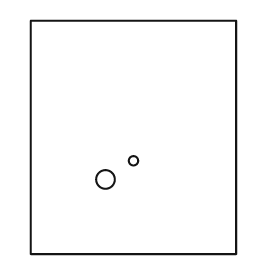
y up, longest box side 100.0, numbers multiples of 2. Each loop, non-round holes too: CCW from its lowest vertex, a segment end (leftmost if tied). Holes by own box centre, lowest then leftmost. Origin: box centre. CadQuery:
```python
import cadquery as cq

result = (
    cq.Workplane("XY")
    .moveTo(-44.0, -50.0)
    .lineTo(44.0, -50.0)
    .lineTo(44.0, 50.0)
    .lineTo(-44.0, 50.0)
    .close()
    .moveTo(-12.0, -18.0)
    .circle(4.0)
    .moveTo(0.0, -10.0)
    .circle(2.0)
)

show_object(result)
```